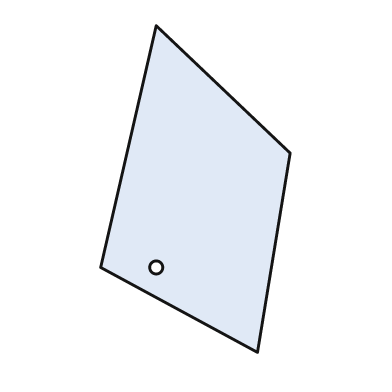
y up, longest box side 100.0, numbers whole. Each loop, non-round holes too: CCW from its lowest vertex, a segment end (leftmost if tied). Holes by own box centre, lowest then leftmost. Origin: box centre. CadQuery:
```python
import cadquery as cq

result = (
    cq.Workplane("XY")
    .moveTo(19.0, -50.0)
    .lineTo(29.0, 11.0)
    .lineTo(-12.0, 50.0)
    .lineTo(-29.0, -24.0)
    .close()
    .moveTo(-12.0, -24.0)
    .circle(2.0)
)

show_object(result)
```